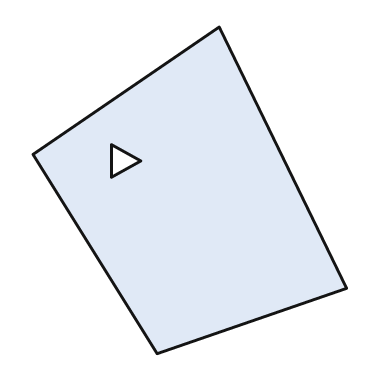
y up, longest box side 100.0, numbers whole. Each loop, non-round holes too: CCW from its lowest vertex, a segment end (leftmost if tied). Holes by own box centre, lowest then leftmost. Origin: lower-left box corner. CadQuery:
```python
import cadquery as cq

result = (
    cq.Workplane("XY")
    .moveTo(38.0, 0.0)
    .lineTo(96.0, 20.0)
    .lineTo(57.0, 100.0)
    .lineTo(0.0, 61.0)
    .close()
    .moveTo(24.0, 54.0)
    .lineTo(33.0, 59.0)
    .lineTo(24.0, 64.0)
    .close()
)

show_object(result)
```